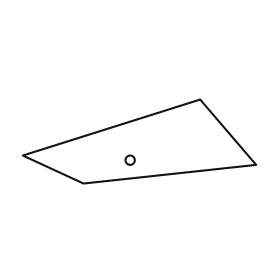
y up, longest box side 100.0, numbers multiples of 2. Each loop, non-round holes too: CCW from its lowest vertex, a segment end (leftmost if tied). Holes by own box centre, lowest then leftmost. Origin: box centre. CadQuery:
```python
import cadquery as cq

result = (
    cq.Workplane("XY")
    .moveTo(-24.0, -18.0)
    .lineTo(50.0, -10.0)
    .lineTo(26.0, 18.0)
    .lineTo(-50.0, -6.0)
    .close()
    .moveTo(-4.0, -8.0)
    .circle(2.0)
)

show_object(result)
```